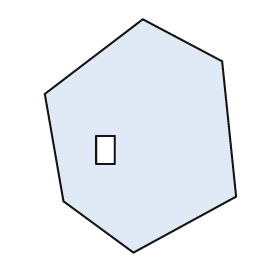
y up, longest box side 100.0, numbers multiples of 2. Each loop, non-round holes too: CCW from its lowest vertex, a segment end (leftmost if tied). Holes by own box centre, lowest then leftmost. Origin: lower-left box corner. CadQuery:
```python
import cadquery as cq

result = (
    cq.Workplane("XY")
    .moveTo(38.0, 0.0)
    .lineTo(82.0, 24.0)
    .lineTo(76.0, 82.0)
    .lineTo(42.0, 100.0)
    .lineTo(0.0, 68.0)
    .lineTo(8.0, 22.0)
    .close()
    .moveTo(22.0, 38.0)
    .lineTo(30.0, 38.0)
    .lineTo(30.0, 50.0)
    .lineTo(22.0, 50.0)
    .close()
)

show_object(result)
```